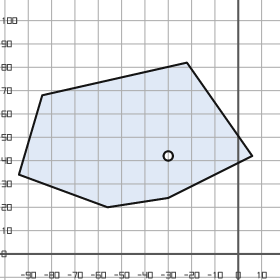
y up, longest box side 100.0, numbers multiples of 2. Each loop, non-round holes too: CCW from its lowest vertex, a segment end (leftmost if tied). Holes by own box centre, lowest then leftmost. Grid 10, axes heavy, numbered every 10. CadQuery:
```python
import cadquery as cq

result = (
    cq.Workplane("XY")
    .moveTo(-56.0, 20.0)
    .lineTo(-30.0, 24.0)
    .lineTo(6.0, 42.0)
    .lineTo(-22.0, 82.0)
    .lineTo(-84.0, 68.0)
    .lineTo(-94.0, 34.0)
    .close()
    .moveTo(-30.0, 42.0)
    .circle(2.0)
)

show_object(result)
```